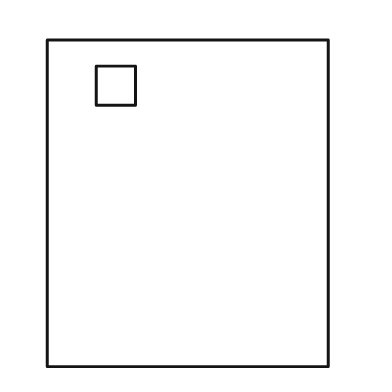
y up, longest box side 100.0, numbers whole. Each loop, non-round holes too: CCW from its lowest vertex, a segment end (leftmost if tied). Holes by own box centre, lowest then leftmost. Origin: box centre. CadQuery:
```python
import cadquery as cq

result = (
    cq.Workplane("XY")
    .moveTo(-43.0, -50.0)
    .lineTo(43.0, -50.0)
    .lineTo(43.0, 50.0)
    .lineTo(-43.0, 50.0)
    .close()
    .moveTo(-28.0, 30.0)
    .lineTo(-16.0, 30.0)
    .lineTo(-16.0, 42.0)
    .lineTo(-28.0, 42.0)
    .close()
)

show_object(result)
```